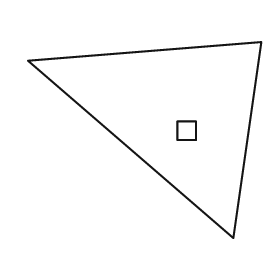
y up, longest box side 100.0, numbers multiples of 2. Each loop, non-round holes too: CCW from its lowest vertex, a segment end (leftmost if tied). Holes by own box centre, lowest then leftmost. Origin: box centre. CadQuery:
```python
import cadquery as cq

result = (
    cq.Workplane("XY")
    .moveTo(38.0, -42.0)
    .lineTo(50.0, 42.0)
    .lineTo(-50.0, 34.0)
    .close()
    .moveTo(14.0, 0.0)
    .lineTo(22.0, 0.0)
    .lineTo(22.0, 8.0)
    .lineTo(14.0, 8.0)
    .close()
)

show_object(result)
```